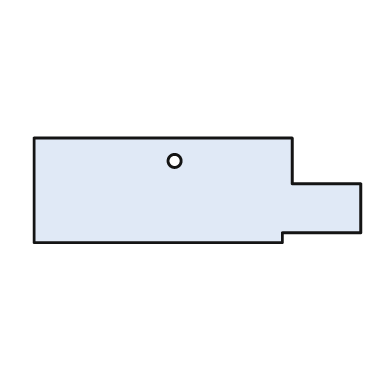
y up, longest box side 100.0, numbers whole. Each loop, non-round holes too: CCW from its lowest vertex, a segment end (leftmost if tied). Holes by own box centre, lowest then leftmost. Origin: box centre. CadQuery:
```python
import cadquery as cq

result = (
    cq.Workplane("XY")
    .moveTo(-50.0, -16.0)
    .lineTo(26.0, -16.0)
    .lineTo(26.0, -13.0)
    .lineTo(50.0, -13.0)
    .lineTo(50.0, 2.0)
    .lineTo(29.0, 2.0)
    .lineTo(29.0, 16.0)
    .lineTo(-50.0, 16.0)
    .close()
    .moveTo(-7.0, 9.0)
    .circle(2.0)
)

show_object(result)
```